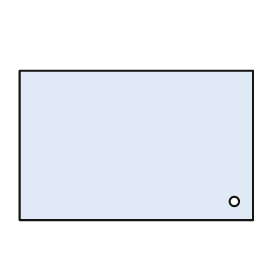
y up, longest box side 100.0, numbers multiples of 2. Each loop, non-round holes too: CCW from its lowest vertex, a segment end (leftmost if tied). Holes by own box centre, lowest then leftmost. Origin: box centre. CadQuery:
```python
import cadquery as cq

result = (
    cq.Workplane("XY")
    .moveTo(-50.0, -32.0)
    .lineTo(50.0, -32.0)
    .lineTo(50.0, 32.0)
    .lineTo(-50.0, 32.0)
    .close()
    .moveTo(42.0, -24.0)
    .circle(2.0)
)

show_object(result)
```